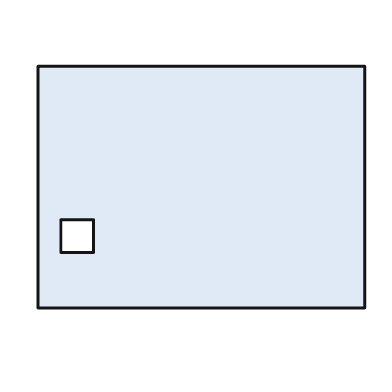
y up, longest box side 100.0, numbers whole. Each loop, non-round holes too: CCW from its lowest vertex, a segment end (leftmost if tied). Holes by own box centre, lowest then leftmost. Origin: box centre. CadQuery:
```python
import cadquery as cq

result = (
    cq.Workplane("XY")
    .moveTo(-50.0, -37.0)
    .lineTo(50.0, -37.0)
    .lineTo(50.0, 37.0)
    .lineTo(-50.0, 37.0)
    .close()
    .moveTo(-43.0, -20.0)
    .lineTo(-33.0, -20.0)
    .lineTo(-33.0, -10.0)
    .lineTo(-43.0, -10.0)
    .close()
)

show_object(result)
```